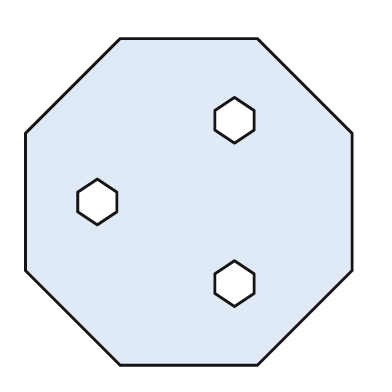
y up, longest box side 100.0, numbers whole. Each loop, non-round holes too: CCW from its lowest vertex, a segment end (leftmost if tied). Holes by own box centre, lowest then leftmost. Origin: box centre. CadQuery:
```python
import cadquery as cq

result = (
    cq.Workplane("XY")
    .moveTo(-21.0, -50.0)
    .lineTo(21.0, -50.0)
    .lineTo(50.0, -21.0)
    .lineTo(50.0, 21.0)
    .lineTo(21.0, 50.0)
    .lineTo(-21.0, 50.0)
    .lineTo(-50.0, 21.0)
    .lineTo(-50.0, -21.0)
    .close()
    .moveTo(14.0, -32.0)
    .lineTo(20.0, -28.0)
    .lineTo(20.0, -22.0)
    .lineTo(14.0, -18.0)
    .lineTo(8.0, -22.0)
    .lineTo(8.0, -28.0)
    .close()
    .moveTo(-28.0, -7.0)
    .lineTo(-22.0, -3.0)
    .lineTo(-22.0, 3.0)
    .lineTo(-28.0, 7.0)
    .lineTo(-34.0, 3.0)
    .lineTo(-34.0, -3.0)
    .close()
    .moveTo(14.0, 18.0)
    .lineTo(20.0, 22.0)
    .lineTo(20.0, 28.0)
    .lineTo(14.0, 32.0)
    .lineTo(8.0, 28.0)
    .lineTo(8.0, 22.0)
    .close()
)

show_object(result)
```